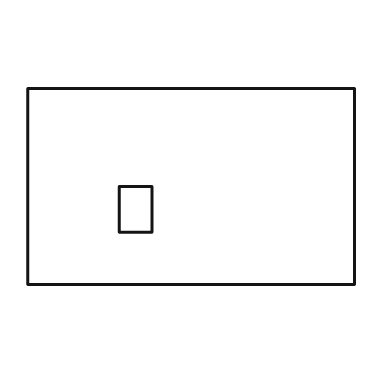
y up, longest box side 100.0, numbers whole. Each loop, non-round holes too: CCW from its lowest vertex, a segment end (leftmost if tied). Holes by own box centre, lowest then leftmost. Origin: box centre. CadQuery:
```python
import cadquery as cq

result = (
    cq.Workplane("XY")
    .moveTo(-50.0, -30.0)
    .lineTo(50.0, -30.0)
    .lineTo(50.0, 30.0)
    .lineTo(-50.0, 30.0)
    .close()
    .moveTo(-22.0, -14.0)
    .lineTo(-12.0, -14.0)
    .lineTo(-12.0, 0.0)
    .lineTo(-22.0, 0.0)
    .close()
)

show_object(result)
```